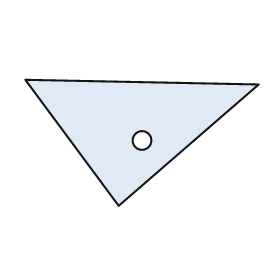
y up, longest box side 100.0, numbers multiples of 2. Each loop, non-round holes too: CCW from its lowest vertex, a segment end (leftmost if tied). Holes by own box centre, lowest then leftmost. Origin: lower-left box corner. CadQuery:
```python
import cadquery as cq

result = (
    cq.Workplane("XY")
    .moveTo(40.0, 0.0)
    .lineTo(100.0, 52.0)
    .lineTo(0.0, 54.0)
    .close()
    .moveTo(50.0, 28.0)
    .circle(4.0)
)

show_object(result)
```